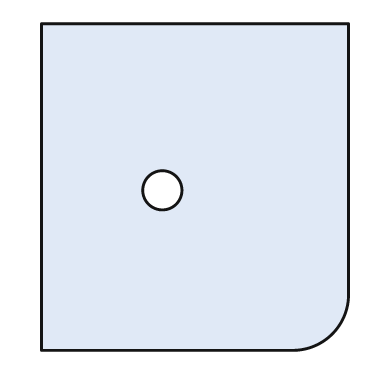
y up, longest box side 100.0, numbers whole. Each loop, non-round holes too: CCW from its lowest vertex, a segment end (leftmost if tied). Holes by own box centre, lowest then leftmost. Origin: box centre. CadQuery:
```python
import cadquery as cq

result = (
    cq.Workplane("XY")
    .moveTo(-47.0, -50.0)
    .lineTo(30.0, -50.0)
    .threePointArc((42.0, -45.0), (47.0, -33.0))
    .lineTo(47.0, 50.0)
    .lineTo(-47.0, 50.0)
    .close()
    .moveTo(-10.0, -1.0)
    .circle(6.0)
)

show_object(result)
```